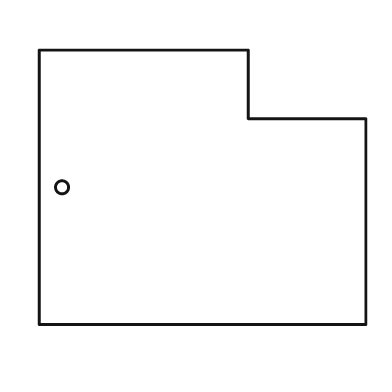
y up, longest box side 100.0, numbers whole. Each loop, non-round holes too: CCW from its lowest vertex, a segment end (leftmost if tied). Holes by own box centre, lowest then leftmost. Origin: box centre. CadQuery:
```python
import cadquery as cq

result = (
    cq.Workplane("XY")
    .moveTo(-50.0, -42.0)
    .lineTo(50.0, -42.0)
    .lineTo(50.0, 21.0)
    .lineTo(14.0, 21.0)
    .lineTo(14.0, 42.0)
    .lineTo(-50.0, 42.0)
    .close()
    .moveTo(-43.0, 0.0)
    .circle(2.0)
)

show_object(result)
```